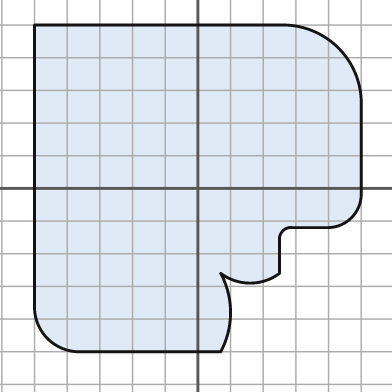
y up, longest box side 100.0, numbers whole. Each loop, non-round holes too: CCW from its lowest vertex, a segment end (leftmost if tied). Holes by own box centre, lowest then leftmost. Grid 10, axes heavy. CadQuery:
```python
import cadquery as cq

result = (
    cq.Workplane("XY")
    .moveTo(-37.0, -50.0)
    .lineTo(7.0, -50.0)
    .threePointArc((10.0, -38.0), (7.0, -26.0))
    .threePointArc((16.0, -29.0), (25.0, -26.0))
    .lineTo(25.0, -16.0)
    .threePointArc((26.0, -13.0), (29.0, -12.0))
    .lineTo(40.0, -12.0)
    .threePointArc((47.0, -9.0), (50.0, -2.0))
    .lineTo(50.0, 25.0)
    .threePointArc((43.0, 43.0), (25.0, 50.0))
    .lineTo(-50.0, 50.0)
    .lineTo(-50.0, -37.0)
    .threePointArc((-46.0, -46.0), (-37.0, -50.0))
    .close()
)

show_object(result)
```